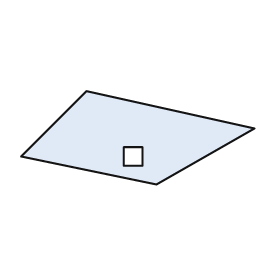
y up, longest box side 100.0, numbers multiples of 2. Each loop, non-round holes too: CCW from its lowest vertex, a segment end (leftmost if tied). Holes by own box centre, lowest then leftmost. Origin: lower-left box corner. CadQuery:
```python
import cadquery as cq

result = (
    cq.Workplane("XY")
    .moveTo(58.0, 0.0)
    .lineTo(100.0, 24.0)
    .lineTo(28.0, 40.0)
    .lineTo(0.0, 12.0)
    .close()
    .moveTo(44.0, 8.0)
    .lineTo(52.0, 8.0)
    .lineTo(52.0, 16.0)
    .lineTo(44.0, 16.0)
    .close()
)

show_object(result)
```